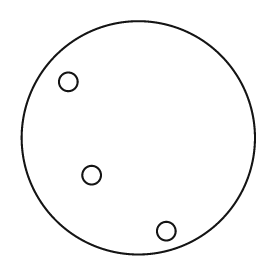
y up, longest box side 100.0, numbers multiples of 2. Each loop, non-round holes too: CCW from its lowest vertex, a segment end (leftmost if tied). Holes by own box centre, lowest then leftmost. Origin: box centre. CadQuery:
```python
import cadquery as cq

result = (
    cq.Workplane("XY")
    .moveTo(0.0, 0.0)
    .circle(50.0)
    .moveTo(12.0, -40.0)
    .circle(4.0)
    .moveTo(-20.0, -16.0)
    .circle(4.0)
    .moveTo(-30.0, 24.0)
    .circle(4.0)
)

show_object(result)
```